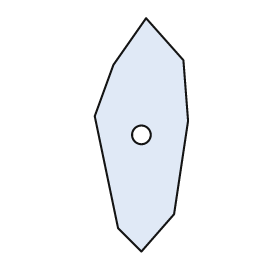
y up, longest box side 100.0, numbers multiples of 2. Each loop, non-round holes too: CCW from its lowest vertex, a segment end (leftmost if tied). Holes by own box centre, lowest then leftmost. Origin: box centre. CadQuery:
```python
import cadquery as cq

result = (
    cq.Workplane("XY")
    .moveTo(0.0, -50.0)
    .lineTo(14.0, -34.0)
    .lineTo(20.0, 6.0)
    .lineTo(18.0, 32.0)
    .lineTo(2.0, 50.0)
    .lineTo(-12.0, 30.0)
    .lineTo(-20.0, 8.0)
    .lineTo(-10.0, -40.0)
    .close()
    .moveTo(0.0, 0.0)
    .circle(4.0)
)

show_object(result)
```